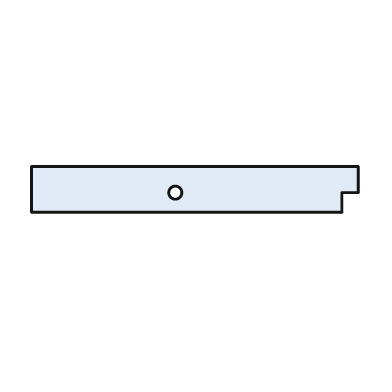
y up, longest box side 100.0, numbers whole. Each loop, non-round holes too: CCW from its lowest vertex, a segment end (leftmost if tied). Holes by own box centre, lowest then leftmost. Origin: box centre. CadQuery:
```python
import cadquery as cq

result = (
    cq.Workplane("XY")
    .moveTo(-50.0, -7.0)
    .lineTo(45.0, -7.0)
    .lineTo(45.0, -1.0)
    .lineTo(50.0, -1.0)
    .lineTo(50.0, 7.0)
    .lineTo(-50.0, 7.0)
    .close()
    .moveTo(-6.0, -1.0)
    .circle(2.0)
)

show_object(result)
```